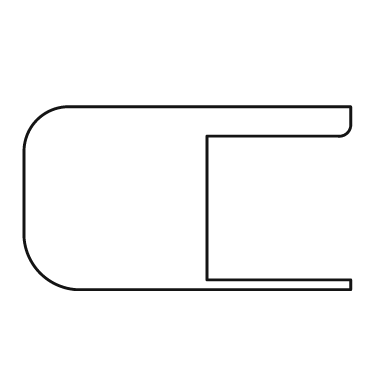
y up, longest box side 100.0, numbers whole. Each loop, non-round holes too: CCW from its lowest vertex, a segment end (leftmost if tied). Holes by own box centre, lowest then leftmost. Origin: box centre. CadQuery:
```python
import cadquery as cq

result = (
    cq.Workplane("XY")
    .moveTo(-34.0, -28.0)
    .lineTo(50.0, -28.0)
    .lineTo(50.0, -25.0)
    .lineTo(6.0, -25.0)
    .lineTo(6.0, 19.0)
    .lineTo(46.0, 19.0)
    .threePointArc((49.0, 20.0), (50.0, 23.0))
    .lineTo(50.0, 28.0)
    .lineTo(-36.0, 28.0)
    .threePointArc((-46.0, 24.0), (-50.0, 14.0))
    .lineTo(-50.0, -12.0)
    .threePointArc((-45.0, -23.0), (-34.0, -28.0))
    .close()
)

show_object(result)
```